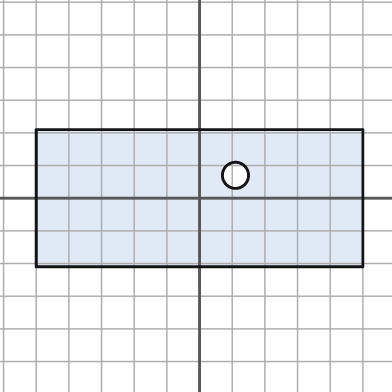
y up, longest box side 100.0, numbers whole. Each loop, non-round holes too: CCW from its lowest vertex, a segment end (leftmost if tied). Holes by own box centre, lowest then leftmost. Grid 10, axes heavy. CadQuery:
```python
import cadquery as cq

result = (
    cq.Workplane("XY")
    .moveTo(-50.0, -21.0)
    .lineTo(50.0, -21.0)
    .lineTo(50.0, 21.0)
    .lineTo(-50.0, 21.0)
    .close()
    .moveTo(11.0, 7.0)
    .circle(4.0)
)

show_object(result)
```